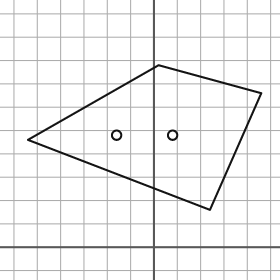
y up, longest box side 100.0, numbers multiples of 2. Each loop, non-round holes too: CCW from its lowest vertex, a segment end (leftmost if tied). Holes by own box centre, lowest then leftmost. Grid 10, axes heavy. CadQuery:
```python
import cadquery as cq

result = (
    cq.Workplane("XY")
    .moveTo(24.0, 16.0)
    .lineTo(46.0, 66.0)
    .lineTo(2.0, 78.0)
    .lineTo(-54.0, 46.0)
    .close()
    .moveTo(-16.0, 48.0)
    .circle(2.0)
    .moveTo(8.0, 48.0)
    .circle(2.0)
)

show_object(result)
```